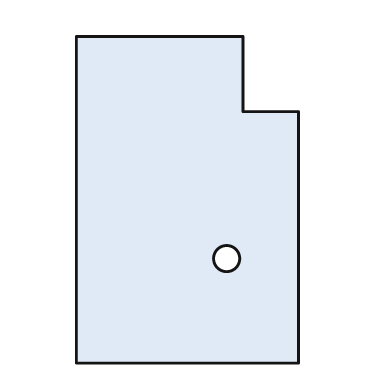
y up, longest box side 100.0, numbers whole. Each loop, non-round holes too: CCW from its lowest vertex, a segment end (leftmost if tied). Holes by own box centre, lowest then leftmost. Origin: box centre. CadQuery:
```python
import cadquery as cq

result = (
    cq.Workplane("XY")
    .moveTo(-34.0, -50.0)
    .lineTo(34.0, -50.0)
    .lineTo(34.0, 27.0)
    .lineTo(17.0, 27.0)
    .lineTo(17.0, 50.0)
    .lineTo(-34.0, 50.0)
    .close()
    .moveTo(12.0, -18.0)
    .circle(4.0)
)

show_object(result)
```